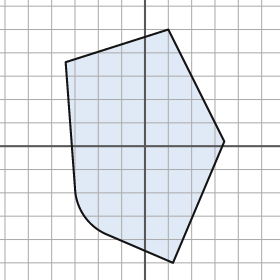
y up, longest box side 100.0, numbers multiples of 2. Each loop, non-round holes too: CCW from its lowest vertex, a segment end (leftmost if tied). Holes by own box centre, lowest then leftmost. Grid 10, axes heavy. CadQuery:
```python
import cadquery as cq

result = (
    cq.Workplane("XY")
    .moveTo(12.0, -50.0)
    .lineTo(34.0, 2.0)
    .lineTo(10.0, 50.0)
    .lineTo(-34.0, 36.0)
    .lineTo(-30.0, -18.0)
    .threePointArc((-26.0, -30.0), (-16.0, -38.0))
    .close()
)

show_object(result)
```